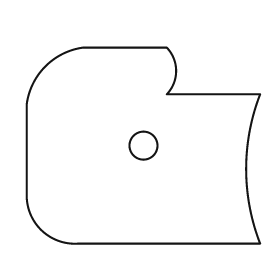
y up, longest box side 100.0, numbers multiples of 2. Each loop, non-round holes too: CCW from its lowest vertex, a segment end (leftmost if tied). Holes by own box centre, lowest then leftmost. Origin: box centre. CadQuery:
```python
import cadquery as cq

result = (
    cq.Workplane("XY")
    .moveTo(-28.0, -42.0)
    .lineTo(50.0, -42.0)
    .threePointArc((44.0, -10.0), (50.0, 22.0))
    .lineTo(10.0, 22.0)
    .threePointArc((14.0, 32.0), (10.0, 42.0))
    .lineTo(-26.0, 42.0)
    .threePointArc((-42.0, 34.0), (-50.0, 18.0))
    .lineTo(-50.0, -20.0)
    .threePointArc((-44.0, -36.0), (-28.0, -42.0))
    .close()
    .moveTo(0.0, 0.0)
    .circle(6.0)
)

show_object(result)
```